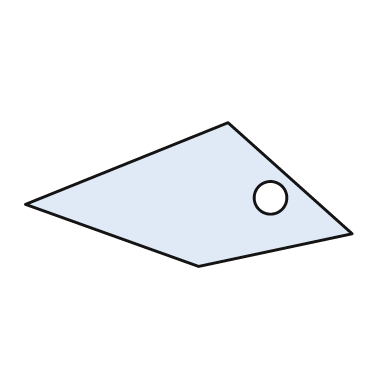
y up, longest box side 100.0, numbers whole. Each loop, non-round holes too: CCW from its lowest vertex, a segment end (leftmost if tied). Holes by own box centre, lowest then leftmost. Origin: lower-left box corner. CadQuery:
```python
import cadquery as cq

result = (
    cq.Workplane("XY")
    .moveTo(53.0, 0.0)
    .lineTo(100.0, 10.0)
    .lineTo(62.0, 44.0)
    .lineTo(0.0, 19.0)
    .close()
    .moveTo(75.0, 21.0)
    .circle(5.0)
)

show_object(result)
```